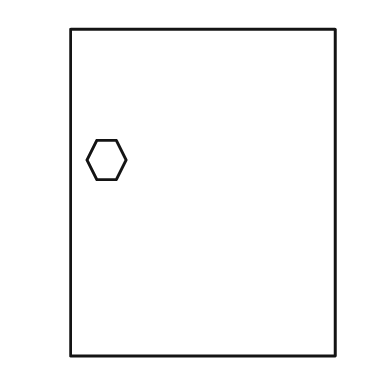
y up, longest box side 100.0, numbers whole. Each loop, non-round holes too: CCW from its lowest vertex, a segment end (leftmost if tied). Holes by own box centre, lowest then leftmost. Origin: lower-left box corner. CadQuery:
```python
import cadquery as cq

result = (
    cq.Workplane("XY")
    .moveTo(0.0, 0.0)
    .lineTo(81.0, 0.0)
    .lineTo(81.0, 100.0)
    .lineTo(0.0, 100.0)
    .close()
    .moveTo(8.0, 54.0)
    .lineTo(14.0, 54.0)
    .lineTo(17.0, 60.0)
    .lineTo(14.0, 66.0)
    .lineTo(8.0, 66.0)
    .lineTo(5.0, 60.0)
    .close()
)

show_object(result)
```